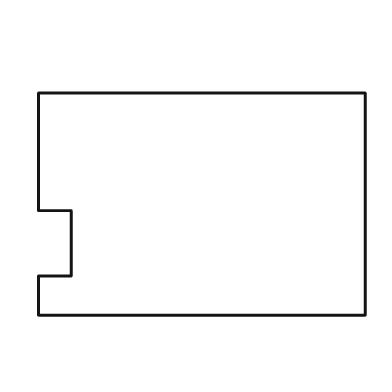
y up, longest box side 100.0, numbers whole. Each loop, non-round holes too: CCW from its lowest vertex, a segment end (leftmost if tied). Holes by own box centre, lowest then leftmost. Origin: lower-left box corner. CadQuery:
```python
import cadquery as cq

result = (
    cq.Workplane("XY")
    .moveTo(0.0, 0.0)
    .lineTo(100.0, 0.0)
    .lineTo(100.0, 68.0)
    .lineTo(0.0, 68.0)
    .lineTo(0.0, 32.0)
    .lineTo(10.0, 32.0)
    .lineTo(10.0, 12.0)
    .lineTo(0.0, 12.0)
    .close()
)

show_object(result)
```